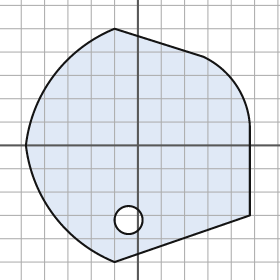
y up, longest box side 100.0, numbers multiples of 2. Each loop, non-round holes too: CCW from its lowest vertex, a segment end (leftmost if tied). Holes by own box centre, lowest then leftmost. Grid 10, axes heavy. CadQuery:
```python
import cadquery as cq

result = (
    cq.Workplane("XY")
    .moveTo(-10.0, -50.0)
    .lineTo(48.0, -30.0)
    .lineTo(48.0, 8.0)
    .threePointArc((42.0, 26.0), (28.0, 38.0))
    .lineTo(-10.0, 50.0)
    .threePointArc((-36.0, 30.0), (-48.0, 0.0))
    .threePointArc((-36.0, -30.0), (-10.0, -50.0))
    .close()
    .moveTo(-4.0, -32.0)
    .circle(6.0)
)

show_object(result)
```